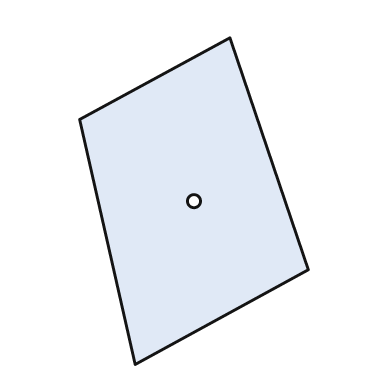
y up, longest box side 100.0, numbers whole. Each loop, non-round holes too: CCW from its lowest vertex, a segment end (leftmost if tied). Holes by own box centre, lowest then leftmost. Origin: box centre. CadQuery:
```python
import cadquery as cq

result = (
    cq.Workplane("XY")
    .moveTo(-18.0, -50.0)
    .lineTo(35.0, -21.0)
    .lineTo(11.0, 50.0)
    .lineTo(-35.0, 25.0)
    .close()
    .moveTo(0.0, 0.0)
    .circle(2.0)
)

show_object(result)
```